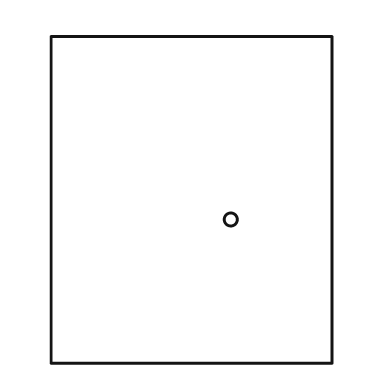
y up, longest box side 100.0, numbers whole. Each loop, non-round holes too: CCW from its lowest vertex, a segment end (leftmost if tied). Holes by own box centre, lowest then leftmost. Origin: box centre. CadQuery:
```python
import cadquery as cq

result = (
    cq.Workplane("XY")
    .moveTo(-43.0, -50.0)
    .lineTo(43.0, -50.0)
    .lineTo(43.0, 50.0)
    .lineTo(-43.0, 50.0)
    .close()
    .moveTo(12.0, -6.0)
    .circle(2.0)
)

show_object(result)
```